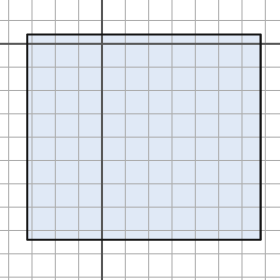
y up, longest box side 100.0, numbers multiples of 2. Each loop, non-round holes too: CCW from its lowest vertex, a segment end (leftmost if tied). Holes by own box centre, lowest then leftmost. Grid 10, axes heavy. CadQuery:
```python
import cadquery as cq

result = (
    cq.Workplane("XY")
    .moveTo(-32.0, -84.0)
    .lineTo(68.0, -84.0)
    .lineTo(68.0, 4.0)
    .lineTo(-32.0, 4.0)
    .close()
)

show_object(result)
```